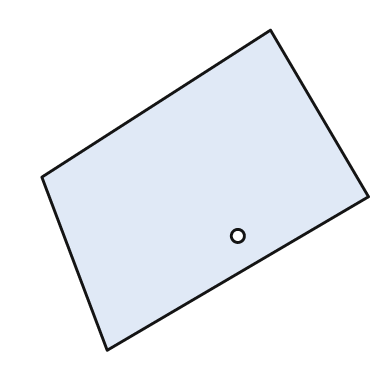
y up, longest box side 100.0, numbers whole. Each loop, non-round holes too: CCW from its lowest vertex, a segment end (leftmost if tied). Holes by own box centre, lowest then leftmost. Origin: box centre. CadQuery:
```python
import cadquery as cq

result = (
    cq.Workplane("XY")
    .moveTo(-30.0, -49.0)
    .lineTo(50.0, -2.0)
    .lineTo(20.0, 49.0)
    .lineTo(-50.0, 4.0)
    .close()
    .moveTo(10.0, -14.0)
    .circle(2.0)
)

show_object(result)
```